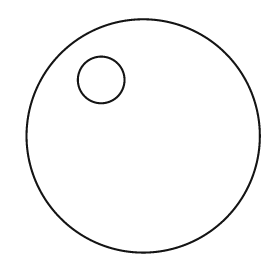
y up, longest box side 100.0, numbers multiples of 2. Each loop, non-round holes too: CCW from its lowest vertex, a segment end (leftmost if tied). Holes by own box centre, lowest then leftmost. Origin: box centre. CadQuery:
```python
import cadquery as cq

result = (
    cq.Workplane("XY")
    .moveTo(0.0, 0.0)
    .circle(50.0)
    .moveTo(-18.0, 24.0)
    .circle(10.0)
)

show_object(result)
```